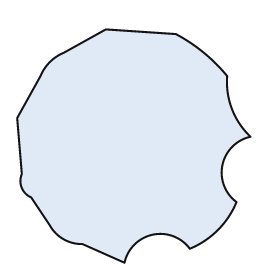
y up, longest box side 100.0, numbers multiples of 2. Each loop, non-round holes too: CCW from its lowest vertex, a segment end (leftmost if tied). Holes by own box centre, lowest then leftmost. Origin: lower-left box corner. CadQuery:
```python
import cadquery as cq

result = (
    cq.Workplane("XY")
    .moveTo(46.0, 0.0)
    .threePointArc((58.0, 12.0), (74.0, 6.0))
    .threePointArc((86.0, 14.0), (94.0, 26.0))
    .threePointArc((88.0, 42.0), (100.0, 54.0))
    .threePointArc((92.0, 66.0), (90.0, 80.0))
    .threePointArc((80.0, 90.0), (68.0, 98.0))
    .lineTo(38.0, 100.0)
    .lineTo(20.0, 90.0)
    .threePointArc((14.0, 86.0), (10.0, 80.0))
    .lineTo(0.0, 62.0)
    .lineTo(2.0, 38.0)
    .threePointArc((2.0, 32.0), (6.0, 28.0))
    .lineTo(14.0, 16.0)
    .threePointArc((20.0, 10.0), (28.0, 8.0))
    .close()
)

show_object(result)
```